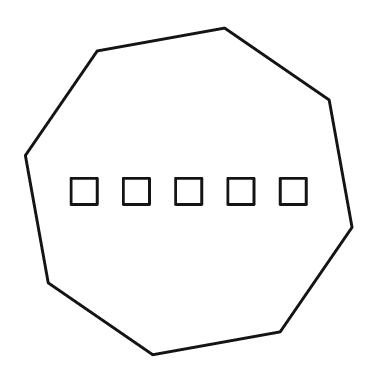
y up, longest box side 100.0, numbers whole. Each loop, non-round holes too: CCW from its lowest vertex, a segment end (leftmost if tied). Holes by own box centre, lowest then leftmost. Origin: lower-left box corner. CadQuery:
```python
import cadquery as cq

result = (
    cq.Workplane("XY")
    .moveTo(39.0, 0.0)
    .lineTo(78.0, 7.0)
    .lineTo(100.0, 39.0)
    .lineTo(93.0, 78.0)
    .lineTo(61.0, 100.0)
    .lineTo(22.0, 93.0)
    .lineTo(0.0, 61.0)
    .lineTo(7.0, 22.0)
    .close()
    .moveTo(14.0, 46.0)
    .lineTo(22.0, 46.0)
    .lineTo(22.0, 54.0)
    .lineTo(14.0, 54.0)
    .close()
    .moveTo(30.0, 46.0)
    .lineTo(38.0, 46.0)
    .lineTo(38.0, 54.0)
    .lineTo(30.0, 54.0)
    .close()
    .moveTo(46.0, 46.0)
    .lineTo(54.0, 46.0)
    .lineTo(54.0, 54.0)
    .lineTo(46.0, 54.0)
    .close()
    .moveTo(62.0, 46.0)
    .lineTo(70.0, 46.0)
    .lineTo(70.0, 54.0)
    .lineTo(62.0, 54.0)
    .close()
    .moveTo(78.0, 46.0)
    .lineTo(86.0, 46.0)
    .lineTo(86.0, 54.0)
    .lineTo(78.0, 54.0)
    .close()
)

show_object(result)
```